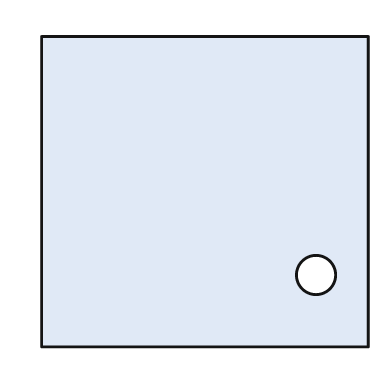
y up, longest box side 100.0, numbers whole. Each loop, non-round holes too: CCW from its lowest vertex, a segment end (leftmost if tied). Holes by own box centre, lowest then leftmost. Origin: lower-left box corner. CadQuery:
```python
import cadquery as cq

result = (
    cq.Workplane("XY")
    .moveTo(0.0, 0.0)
    .lineTo(100.0, 0.0)
    .lineTo(100.0, 95.0)
    .lineTo(0.0, 95.0)
    .close()
    .moveTo(84.0, 22.0)
    .circle(6.0)
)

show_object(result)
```